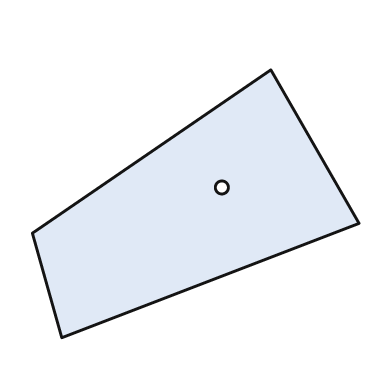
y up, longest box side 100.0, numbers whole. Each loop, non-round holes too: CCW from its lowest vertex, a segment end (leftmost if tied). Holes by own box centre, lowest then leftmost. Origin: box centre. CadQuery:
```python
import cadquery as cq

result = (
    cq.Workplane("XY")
    .moveTo(-41.0, -41.0)
    .lineTo(50.0, -6.0)
    .lineTo(23.0, 41.0)
    .lineTo(-50.0, -9.0)
    .close()
    .moveTo(8.0, 5.0)
    .circle(2.0)
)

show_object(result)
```